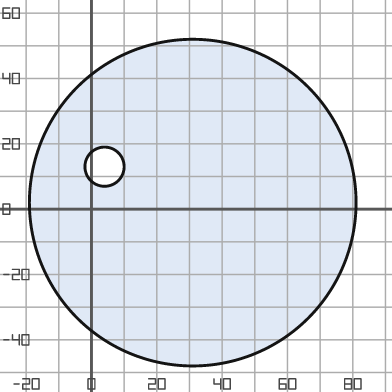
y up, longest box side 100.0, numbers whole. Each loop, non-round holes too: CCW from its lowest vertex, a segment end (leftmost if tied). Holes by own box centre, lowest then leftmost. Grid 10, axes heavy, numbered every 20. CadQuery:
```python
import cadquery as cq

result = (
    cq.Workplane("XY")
    .moveTo(31.0, 2.0)
    .circle(50.0)
    .moveTo(4.0, 13.0)
    .circle(6.0)
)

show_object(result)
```